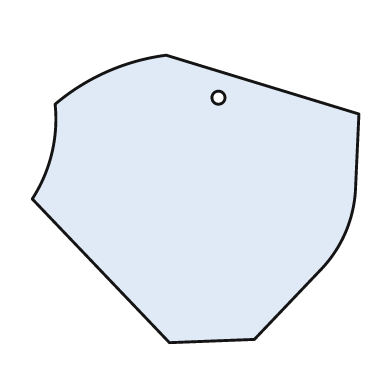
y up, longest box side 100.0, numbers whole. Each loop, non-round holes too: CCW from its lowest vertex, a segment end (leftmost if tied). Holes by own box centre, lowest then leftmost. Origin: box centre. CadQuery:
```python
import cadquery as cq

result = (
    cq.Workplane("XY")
    .moveTo(-8.0, -44.0)
    .lineTo(18.0, -43.0)
    .lineTo(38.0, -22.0)
    .threePointArc((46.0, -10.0), (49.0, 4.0))
    .lineTo(50.0, 26.0)
    .lineTo(-9.0, 44.0)
    .threePointArc((-27.0, 39.0), (-43.0, 29.0))
    .threePointArc((-44.0, 14.0), (-50.0, 0.0))
    .close()
    .moveTo(7.0, 31.0)
    .circle(2.0)
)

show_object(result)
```